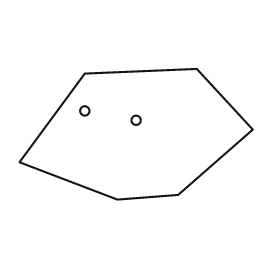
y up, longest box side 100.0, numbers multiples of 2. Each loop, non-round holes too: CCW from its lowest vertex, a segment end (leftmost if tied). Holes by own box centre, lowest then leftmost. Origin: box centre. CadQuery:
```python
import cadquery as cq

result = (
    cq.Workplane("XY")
    .moveTo(-8.0, -28.0)
    .lineTo(18.0, -26.0)
    .lineTo(50.0, 2.0)
    .lineTo(26.0, 28.0)
    .lineTo(-22.0, 26.0)
    .lineTo(-50.0, -12.0)
    .close()
    .moveTo(0.0, 6.0)
    .circle(2.0)
    .moveTo(-22.0, 10.0)
    .circle(2.0)
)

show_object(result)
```